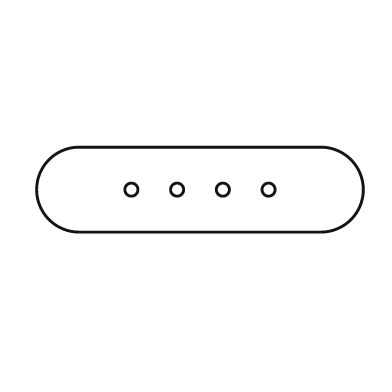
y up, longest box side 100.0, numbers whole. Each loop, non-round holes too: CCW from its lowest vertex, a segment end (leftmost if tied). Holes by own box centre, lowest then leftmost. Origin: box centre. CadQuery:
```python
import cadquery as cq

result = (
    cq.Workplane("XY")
    .moveTo(-37.0, -13.0)
    .lineTo(37.0, -13.0)
    .threePointArc((50.0, 0.0), (37.0, 13.0))
    .lineTo(-37.0, 13.0)
    .threePointArc((-50.0, 0.0), (-37.0, -13.0))
    .close()
    .moveTo(-21.0, 0.0)
    .circle(2.0)
    .moveTo(-7.0, 0.0)
    .circle(2.0)
    .moveTo(7.0, 0.0)
    .circle(2.0)
    .moveTo(21.0, 0.0)
    .circle(2.0)
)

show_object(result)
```